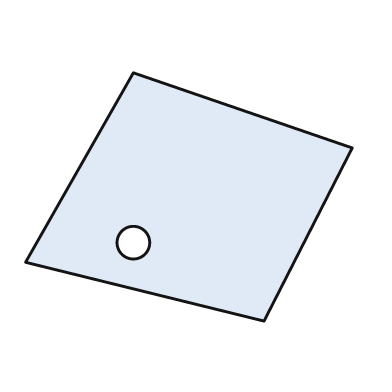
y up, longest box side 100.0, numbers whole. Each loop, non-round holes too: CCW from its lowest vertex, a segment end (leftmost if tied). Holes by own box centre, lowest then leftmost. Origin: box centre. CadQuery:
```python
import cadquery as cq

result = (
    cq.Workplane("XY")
    .moveTo(23.0, -38.0)
    .lineTo(50.0, 15.0)
    .lineTo(-17.0, 38.0)
    .lineTo(-50.0, -20.0)
    .close()
    .moveTo(-17.0, -14.0)
    .circle(5.0)
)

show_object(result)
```